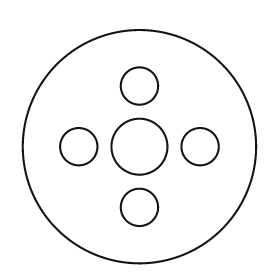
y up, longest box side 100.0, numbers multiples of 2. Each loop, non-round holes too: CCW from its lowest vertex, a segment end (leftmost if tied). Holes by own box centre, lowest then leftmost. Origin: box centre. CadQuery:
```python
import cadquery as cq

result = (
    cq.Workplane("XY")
    .moveTo(0.0, 0.0)
    .circle(50.0)
    .moveTo(0.0, -26.0)
    .circle(8.0)
    .moveTo(-26.0, 0.0)
    .circle(8.0)
    .moveTo(0.0, 0.0)
    .circle(12.0)
    .moveTo(26.0, 0.0)
    .circle(8.0)
    .moveTo(0.0, 26.0)
    .circle(8.0)
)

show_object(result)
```